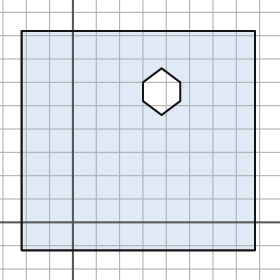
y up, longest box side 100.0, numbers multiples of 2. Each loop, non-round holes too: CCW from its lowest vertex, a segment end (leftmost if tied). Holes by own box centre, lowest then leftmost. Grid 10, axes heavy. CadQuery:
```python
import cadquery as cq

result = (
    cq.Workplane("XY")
    .moveTo(-22.0, -12.0)
    .lineTo(78.0, -12.0)
    .lineTo(78.0, 82.0)
    .lineTo(-22.0, 82.0)
    .close()
    .moveTo(38.0, 46.0)
    .lineTo(46.0, 52.0)
    .lineTo(46.0, 60.0)
    .lineTo(38.0, 66.0)
    .lineTo(30.0, 60.0)
    .lineTo(30.0, 52.0)
    .close()
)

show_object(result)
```